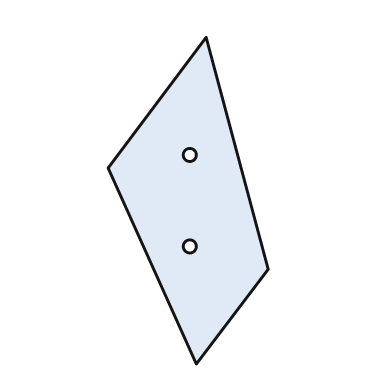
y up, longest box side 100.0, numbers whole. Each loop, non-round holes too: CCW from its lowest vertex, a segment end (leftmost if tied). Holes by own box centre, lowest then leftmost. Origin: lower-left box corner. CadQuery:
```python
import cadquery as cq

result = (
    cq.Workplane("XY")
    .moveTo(27.0, 0.0)
    .lineTo(49.0, 29.0)
    .lineTo(30.0, 100.0)
    .lineTo(0.0, 60.0)
    .close()
    .moveTo(25.0, 36.0)
    .circle(2.0)
    .moveTo(25.0, 64.0)
    .circle(2.0)
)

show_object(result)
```